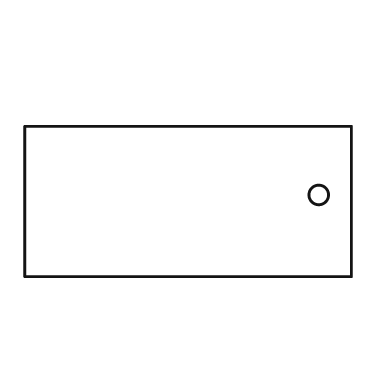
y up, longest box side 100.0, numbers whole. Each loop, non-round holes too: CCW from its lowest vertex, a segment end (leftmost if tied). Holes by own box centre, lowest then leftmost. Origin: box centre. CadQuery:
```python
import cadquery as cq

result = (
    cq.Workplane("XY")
    .moveTo(-50.0, -23.0)
    .lineTo(50.0, -23.0)
    .lineTo(50.0, 23.0)
    .lineTo(-50.0, 23.0)
    .close()
    .moveTo(40.0, 2.0)
    .circle(3.0)
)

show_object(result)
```